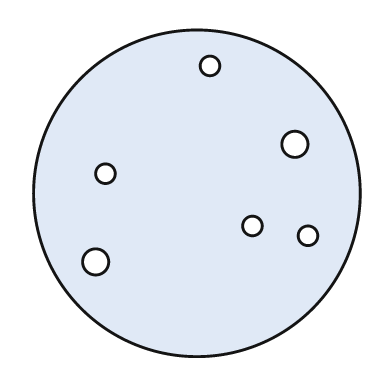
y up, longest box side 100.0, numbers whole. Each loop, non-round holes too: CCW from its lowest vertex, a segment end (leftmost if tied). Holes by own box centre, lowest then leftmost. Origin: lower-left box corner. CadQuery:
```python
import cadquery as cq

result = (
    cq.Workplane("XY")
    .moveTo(50.0, 50.0)
    .circle(50.0)
    .moveTo(19.0, 29.0)
    .circle(4.0)
    .moveTo(84.0, 37.0)
    .circle(3.0)
    .moveTo(67.0, 40.0)
    .circle(3.0)
    .moveTo(22.0, 56.0)
    .circle(3.0)
    .moveTo(80.0, 65.0)
    .circle(4.0)
    .moveTo(54.0, 89.0)
    .circle(3.0)
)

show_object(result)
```